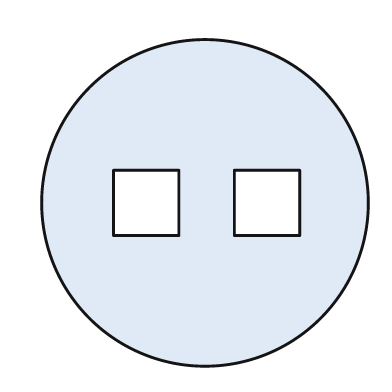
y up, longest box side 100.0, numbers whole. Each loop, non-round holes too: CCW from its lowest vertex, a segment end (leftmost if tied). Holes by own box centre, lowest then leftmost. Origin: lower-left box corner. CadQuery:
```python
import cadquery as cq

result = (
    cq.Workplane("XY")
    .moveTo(50.0, 50.0)
    .circle(50.0)
    .moveTo(22.0, 40.0)
    .lineTo(42.0, 40.0)
    .lineTo(42.0, 60.0)
    .lineTo(22.0, 60.0)
    .close()
    .moveTo(59.0, 40.0)
    .lineTo(79.0, 40.0)
    .lineTo(79.0, 60.0)
    .lineTo(59.0, 60.0)
    .close()
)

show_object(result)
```